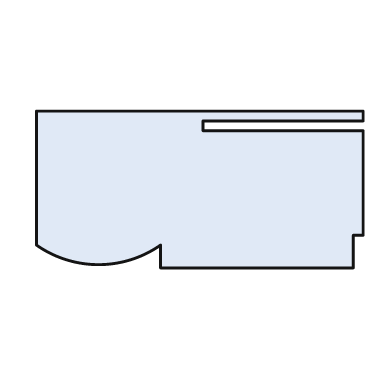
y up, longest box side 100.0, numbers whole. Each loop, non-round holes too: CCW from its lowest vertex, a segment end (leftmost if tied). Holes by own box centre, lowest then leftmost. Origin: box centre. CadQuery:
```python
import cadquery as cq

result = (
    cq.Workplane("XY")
    .moveTo(-12.0, -24.0)
    .lineTo(47.0, -24.0)
    .lineTo(47.0, -14.0)
    .lineTo(50.0, -14.0)
    .lineTo(50.0, 18.0)
    .lineTo(1.0, 18.0)
    .lineTo(1.0, 21.0)
    .lineTo(50.0, 21.0)
    .lineTo(50.0, 24.0)
    .lineTo(-50.0, 24.0)
    .lineTo(-50.0, -17.0)
    .threePointArc((-31.0, -23.0), (-12.0, -17.0))
    .close()
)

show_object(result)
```